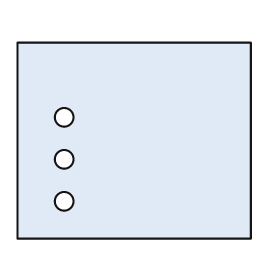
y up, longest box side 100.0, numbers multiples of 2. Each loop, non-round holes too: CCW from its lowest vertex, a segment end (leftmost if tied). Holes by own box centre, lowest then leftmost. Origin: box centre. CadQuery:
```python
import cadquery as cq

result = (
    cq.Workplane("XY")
    .moveTo(-50.0, -42.0)
    .lineTo(50.0, -42.0)
    .lineTo(50.0, 42.0)
    .lineTo(-50.0, 42.0)
    .close()
    .moveTo(-30.0, -26.0)
    .circle(4.0)
    .moveTo(-30.0, -8.0)
    .circle(4.0)
    .moveTo(-30.0, 10.0)
    .circle(4.0)
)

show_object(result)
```